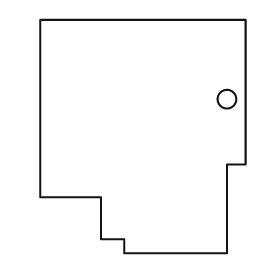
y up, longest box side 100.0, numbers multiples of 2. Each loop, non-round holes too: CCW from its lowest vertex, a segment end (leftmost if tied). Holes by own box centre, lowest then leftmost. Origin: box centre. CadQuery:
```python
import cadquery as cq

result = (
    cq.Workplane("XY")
    .moveTo(-8.0, -50.0)
    .lineTo(36.0, -50.0)
    .lineTo(36.0, -12.0)
    .lineTo(44.0, -12.0)
    .lineTo(44.0, 50.0)
    .lineTo(-44.0, 50.0)
    .lineTo(-44.0, -26.0)
    .lineTo(-18.0, -26.0)
    .lineTo(-18.0, -44.0)
    .lineTo(-8.0, -44.0)
    .close()
    .moveTo(36.0, 16.0)
    .circle(4.0)
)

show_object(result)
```